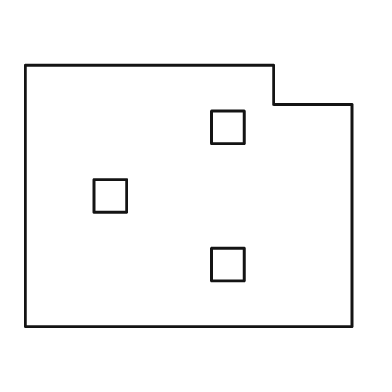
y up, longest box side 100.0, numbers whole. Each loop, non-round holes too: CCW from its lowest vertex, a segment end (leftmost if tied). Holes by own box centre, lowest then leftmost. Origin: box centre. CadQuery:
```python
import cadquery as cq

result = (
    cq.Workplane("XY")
    .moveTo(-50.0, -40.0)
    .lineTo(50.0, -40.0)
    .lineTo(50.0, 28.0)
    .lineTo(26.0, 28.0)
    .lineTo(26.0, 40.0)
    .lineTo(-50.0, 40.0)
    .close()
    .moveTo(7.0, -26.0)
    .lineTo(17.0, -26.0)
    .lineTo(17.0, -16.0)
    .lineTo(7.0, -16.0)
    .close()
    .moveTo(-29.0, -5.0)
    .lineTo(-19.0, -5.0)
    .lineTo(-19.0, 5.0)
    .lineTo(-29.0, 5.0)
    .close()
    .moveTo(7.0, 16.0)
    .lineTo(17.0, 16.0)
    .lineTo(17.0, 26.0)
    .lineTo(7.0, 26.0)
    .close()
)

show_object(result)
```